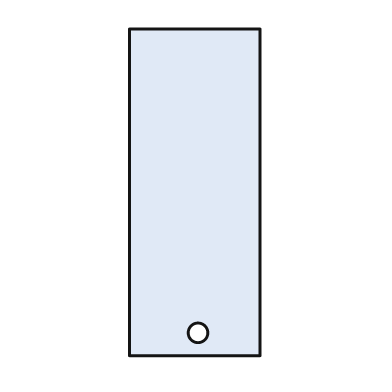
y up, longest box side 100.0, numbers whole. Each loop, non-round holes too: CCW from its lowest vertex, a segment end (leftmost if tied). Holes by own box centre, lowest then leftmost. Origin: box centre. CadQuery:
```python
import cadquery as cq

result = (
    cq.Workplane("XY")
    .moveTo(-20.0, -50.0)
    .lineTo(20.0, -50.0)
    .lineTo(20.0, 50.0)
    .lineTo(-20.0, 50.0)
    .close()
    .moveTo(1.0, -43.0)
    .circle(3.0)
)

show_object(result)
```